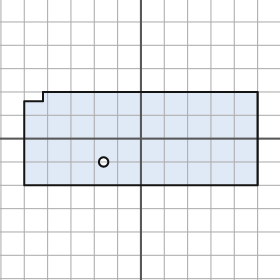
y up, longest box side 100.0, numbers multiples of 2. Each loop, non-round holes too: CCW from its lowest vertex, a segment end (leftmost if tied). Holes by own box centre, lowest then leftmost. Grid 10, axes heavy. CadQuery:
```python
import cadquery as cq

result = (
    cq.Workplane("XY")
    .moveTo(-50.0, -20.0)
    .lineTo(50.0, -20.0)
    .lineTo(50.0, 20.0)
    .lineTo(-42.0, 20.0)
    .lineTo(-42.0, 16.0)
    .lineTo(-50.0, 16.0)
    .close()
    .moveTo(-16.0, -10.0)
    .circle(2.0)
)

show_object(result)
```